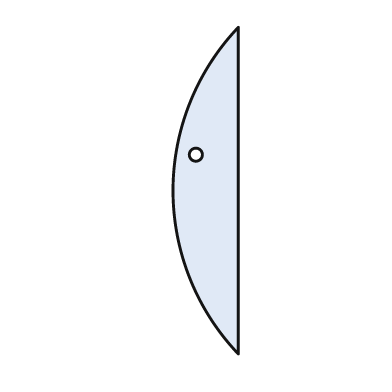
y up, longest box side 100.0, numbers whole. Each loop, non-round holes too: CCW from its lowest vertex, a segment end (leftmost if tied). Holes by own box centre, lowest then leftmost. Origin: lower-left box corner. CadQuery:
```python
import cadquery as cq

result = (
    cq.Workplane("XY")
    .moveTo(20.0, 0.0)
    .lineTo(20.0, 100.0)
    .threePointArc((0.0, 50.0), (20.0, 0.0))
    .close()
    .moveTo(7.0, 61.0)
    .circle(2.0)
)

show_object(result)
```